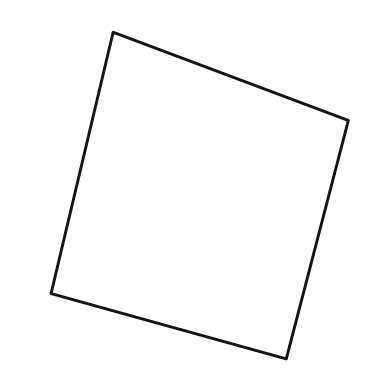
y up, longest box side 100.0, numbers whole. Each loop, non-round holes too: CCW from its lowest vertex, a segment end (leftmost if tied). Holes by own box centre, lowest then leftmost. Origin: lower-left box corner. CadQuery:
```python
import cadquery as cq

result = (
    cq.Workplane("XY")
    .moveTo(72.0, 0.0)
    .lineTo(91.0, 73.0)
    .lineTo(19.0, 100.0)
    .lineTo(0.0, 20.0)
    .close()
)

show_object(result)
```